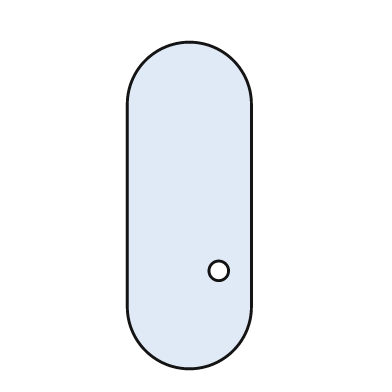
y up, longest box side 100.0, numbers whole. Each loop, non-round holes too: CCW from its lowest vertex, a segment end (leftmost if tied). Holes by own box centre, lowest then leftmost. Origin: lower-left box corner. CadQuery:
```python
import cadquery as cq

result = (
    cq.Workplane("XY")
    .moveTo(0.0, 19.0)
    .threePointArc((19.0, 0.0), (38.0, 19.0))
    .lineTo(38.0, 81.0)
    .threePointArc((19.0, 100.0), (0.0, 81.0))
    .close()
    .moveTo(28.0, 30.0)
    .circle(3.0)
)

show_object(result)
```